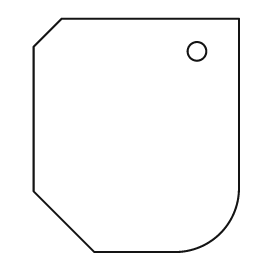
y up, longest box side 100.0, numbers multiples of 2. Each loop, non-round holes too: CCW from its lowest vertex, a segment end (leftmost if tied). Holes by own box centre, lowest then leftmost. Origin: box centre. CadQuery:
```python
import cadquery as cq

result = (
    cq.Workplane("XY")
    .moveTo(-18.0, -50.0)
    .lineTo(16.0, -50.0)
    .threePointArc((36.0, -42.0), (44.0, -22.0))
    .lineTo(44.0, 50.0)
    .lineTo(-32.0, 50.0)
    .lineTo(-44.0, 38.0)
    .lineTo(-44.0, -24.0)
    .close()
    .moveTo(26.0, 36.0)
    .circle(4.0)
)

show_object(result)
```